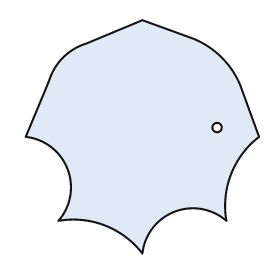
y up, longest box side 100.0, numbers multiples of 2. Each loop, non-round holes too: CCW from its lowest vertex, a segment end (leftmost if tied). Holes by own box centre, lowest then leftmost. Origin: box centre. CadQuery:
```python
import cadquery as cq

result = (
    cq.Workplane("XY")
    .moveTo(0.0, -50.0)
    .threePointArc((14.0, -32.0), (36.0, -36.0))
    .threePointArc((38.0, -16.0), (50.0, 0.0))
    .lineTo(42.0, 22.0)
    .threePointArc((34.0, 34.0), (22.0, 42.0))
    .lineTo(0.0, 50.0)
    .lineTo(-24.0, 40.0)
    .threePointArc((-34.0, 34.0), (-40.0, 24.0))
    .lineTo(-50.0, 0.0)
    .threePointArc((-32.0, -14.0), (-36.0, -36.0))
    .threePointArc((-16.0, -38.0), (0.0, -50.0))
    .close()
    .moveTo(32.0, 4.0)
    .circle(2.0)
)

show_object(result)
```